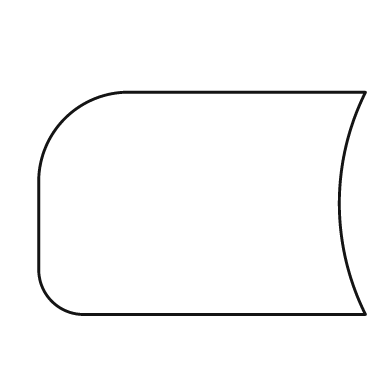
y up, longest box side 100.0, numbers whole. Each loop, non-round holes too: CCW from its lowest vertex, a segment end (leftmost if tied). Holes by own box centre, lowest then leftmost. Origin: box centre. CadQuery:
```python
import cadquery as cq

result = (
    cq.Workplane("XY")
    .moveTo(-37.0, -34.0)
    .lineTo(50.0, -34.0)
    .threePointArc((42.0, 0.0), (50.0, 34.0))
    .lineTo(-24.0, 34.0)
    .threePointArc((-42.0, 26.0), (-50.0, 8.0))
    .lineTo(-50.0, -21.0)
    .threePointArc((-46.0, -30.0), (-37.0, -34.0))
    .close()
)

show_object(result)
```